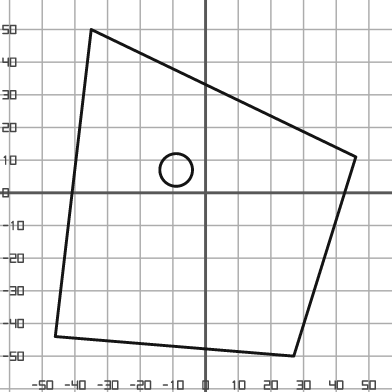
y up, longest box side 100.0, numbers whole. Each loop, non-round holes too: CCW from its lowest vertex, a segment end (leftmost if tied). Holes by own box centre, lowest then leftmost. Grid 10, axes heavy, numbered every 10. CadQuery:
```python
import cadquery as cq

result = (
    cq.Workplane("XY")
    .moveTo(27.0, -50.0)
    .lineTo(46.0, 11.0)
    .lineTo(-35.0, 50.0)
    .lineTo(-46.0, -44.0)
    .close()
    .moveTo(-9.0, 7.0)
    .circle(5.0)
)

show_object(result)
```